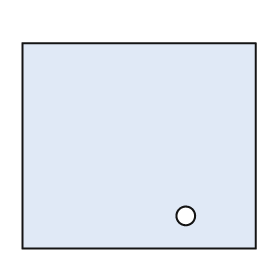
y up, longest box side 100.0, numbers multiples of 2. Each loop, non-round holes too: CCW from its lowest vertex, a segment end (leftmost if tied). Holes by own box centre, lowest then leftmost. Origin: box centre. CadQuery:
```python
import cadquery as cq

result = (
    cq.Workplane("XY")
    .moveTo(-50.0, -44.0)
    .lineTo(50.0, -44.0)
    .lineTo(50.0, 44.0)
    .lineTo(-50.0, 44.0)
    .close()
    .moveTo(20.0, -30.0)
    .circle(4.0)
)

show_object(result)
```